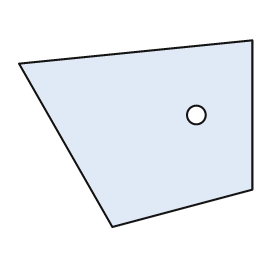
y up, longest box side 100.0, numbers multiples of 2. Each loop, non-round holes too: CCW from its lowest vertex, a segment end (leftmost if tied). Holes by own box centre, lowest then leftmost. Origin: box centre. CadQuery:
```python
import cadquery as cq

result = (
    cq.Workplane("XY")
    .moveTo(-10.0, -40.0)
    .lineTo(50.0, -24.0)
    .lineTo(50.0, 40.0)
    .lineTo(-50.0, 30.0)
    .close()
    .moveTo(26.0, 8.0)
    .circle(4.0)
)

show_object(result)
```